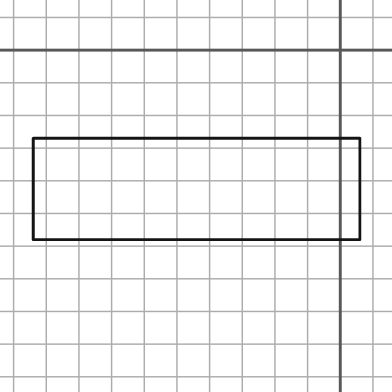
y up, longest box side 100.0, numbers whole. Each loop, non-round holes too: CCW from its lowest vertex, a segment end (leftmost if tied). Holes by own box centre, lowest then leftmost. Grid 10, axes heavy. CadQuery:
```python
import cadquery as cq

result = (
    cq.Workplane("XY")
    .moveTo(-94.0, -58.0)
    .lineTo(6.0, -58.0)
    .lineTo(6.0, -27.0)
    .lineTo(-94.0, -27.0)
    .close()
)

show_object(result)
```